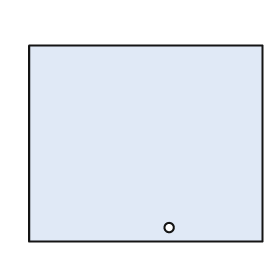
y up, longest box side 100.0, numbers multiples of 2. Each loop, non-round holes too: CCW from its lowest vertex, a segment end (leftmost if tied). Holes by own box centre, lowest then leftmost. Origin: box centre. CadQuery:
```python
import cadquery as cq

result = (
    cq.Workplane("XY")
    .moveTo(-50.0, -42.0)
    .lineTo(50.0, -42.0)
    .lineTo(50.0, 42.0)
    .lineTo(-50.0, 42.0)
    .close()
    .moveTo(10.0, -36.0)
    .circle(2.0)
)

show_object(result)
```